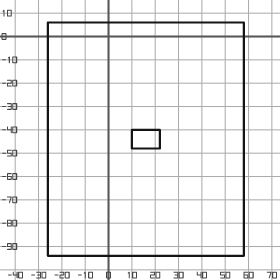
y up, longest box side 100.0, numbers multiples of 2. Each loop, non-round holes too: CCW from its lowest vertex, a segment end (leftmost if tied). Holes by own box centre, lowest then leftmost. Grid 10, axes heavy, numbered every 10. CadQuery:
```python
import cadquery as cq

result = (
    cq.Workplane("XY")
    .moveTo(-26.0, -94.0)
    .lineTo(58.0, -94.0)
    .lineTo(58.0, 6.0)
    .lineTo(-26.0, 6.0)
    .close()
    .moveTo(10.0, -48.0)
    .lineTo(22.0, -48.0)
    .lineTo(22.0, -40.0)
    .lineTo(10.0, -40.0)
    .close()
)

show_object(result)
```